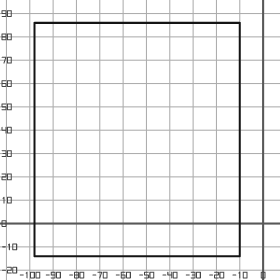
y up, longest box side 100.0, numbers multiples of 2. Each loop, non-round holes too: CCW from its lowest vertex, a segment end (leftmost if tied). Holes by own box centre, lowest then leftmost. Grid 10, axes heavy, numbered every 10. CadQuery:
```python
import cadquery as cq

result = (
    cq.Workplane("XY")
    .moveTo(-98.0, -14.0)
    .lineTo(-10.0, -14.0)
    .lineTo(-10.0, 86.0)
    .lineTo(-98.0, 86.0)
    .close()
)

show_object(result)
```